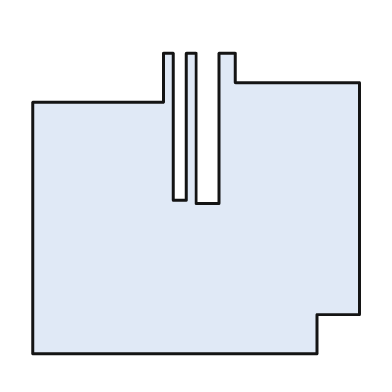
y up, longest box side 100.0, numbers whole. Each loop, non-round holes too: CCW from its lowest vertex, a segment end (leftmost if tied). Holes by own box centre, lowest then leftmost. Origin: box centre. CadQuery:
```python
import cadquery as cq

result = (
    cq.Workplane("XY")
    .moveTo(-50.0, -46.0)
    .lineTo(37.0, -46.0)
    .lineTo(37.0, -34.0)
    .lineTo(50.0, -34.0)
    .lineTo(50.0, 37.0)
    .lineTo(12.0, 37.0)
    .lineTo(12.0, 46.0)
    .lineTo(7.0, 46.0)
    .lineTo(7.0, 0.0)
    .lineTo(0.0, 0.0)
    .lineTo(0.0, 46.0)
    .lineTo(-3.0, 46.0)
    .lineTo(-3.0, 1.0)
    .lineTo(-7.0, 1.0)
    .lineTo(-7.0, 46.0)
    .lineTo(-10.0, 46.0)
    .lineTo(-10.0, 31.0)
    .lineTo(-50.0, 31.0)
    .close()
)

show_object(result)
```